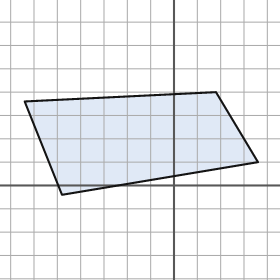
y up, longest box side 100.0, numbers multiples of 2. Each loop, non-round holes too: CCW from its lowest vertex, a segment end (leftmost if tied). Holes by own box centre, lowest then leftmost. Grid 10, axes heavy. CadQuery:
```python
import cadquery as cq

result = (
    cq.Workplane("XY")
    .moveTo(-48.0, -4.0)
    .lineTo(36.0, 10.0)
    .lineTo(18.0, 40.0)
    .lineTo(-64.0, 36.0)
    .close()
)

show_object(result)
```